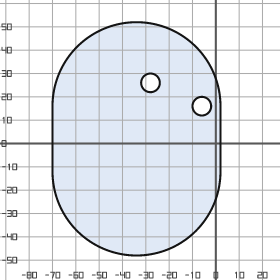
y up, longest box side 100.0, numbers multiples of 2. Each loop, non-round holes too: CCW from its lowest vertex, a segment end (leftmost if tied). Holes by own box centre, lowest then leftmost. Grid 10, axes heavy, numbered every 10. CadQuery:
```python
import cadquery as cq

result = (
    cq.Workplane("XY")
    .moveTo(-70.0, -12.0)
    .threePointArc((-34.0, -48.0), (2.0, -12.0))
    .lineTo(2.0, 16.0)
    .threePointArc((-34.0, 52.0), (-70.0, 16.0))
    .close()
    .moveTo(-6.0, 16.0)
    .circle(4.0)
    .moveTo(-28.0, 26.0)
    .circle(4.0)
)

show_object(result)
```